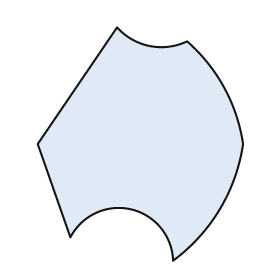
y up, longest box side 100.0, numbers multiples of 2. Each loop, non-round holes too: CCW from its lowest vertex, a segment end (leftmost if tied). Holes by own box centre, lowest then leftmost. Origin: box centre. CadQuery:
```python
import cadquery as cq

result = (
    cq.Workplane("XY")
    .moveTo(14.0, -50.0)
    .threePointArc((34.0, -28.0), (44.0, 0.0))
    .threePointArc((36.0, 24.0), (20.0, 44.0))
    .threePointArc((4.0, 42.0), (-10.0, 50.0))
    .lineTo(-44.0, 0.0)
    .lineTo(-30.0, -40.0)
    .threePointArc((-4.0, -28.0), (14.0, -50.0))
    .close()
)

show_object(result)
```